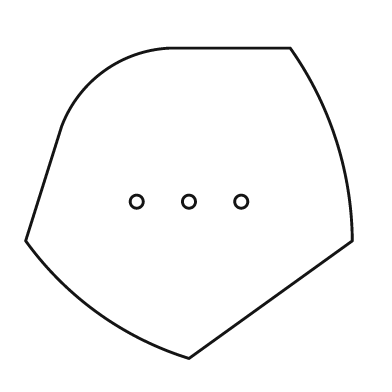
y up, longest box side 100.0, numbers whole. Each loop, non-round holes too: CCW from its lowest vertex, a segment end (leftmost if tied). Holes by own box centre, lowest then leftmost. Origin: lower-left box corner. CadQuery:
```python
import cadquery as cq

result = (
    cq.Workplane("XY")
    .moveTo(50.0, 0.0)
    .lineTo(100.0, 36.0)
    .threePointArc((95.0, 67.0), (81.0, 95.0))
    .lineTo(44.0, 95.0)
    .threePointArc((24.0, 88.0), (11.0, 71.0))
    .lineTo(0.0, 36.0)
    .threePointArc((22.0, 14.0), (50.0, 0.0))
    .close()
    .moveTo(34.0, 48.0)
    .circle(2.0)
    .moveTo(50.0, 48.0)
    .circle(2.0)
    .moveTo(66.0, 48.0)
    .circle(2.0)
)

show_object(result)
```